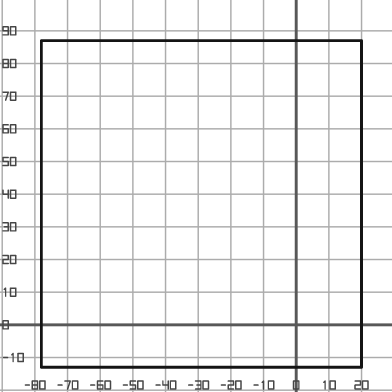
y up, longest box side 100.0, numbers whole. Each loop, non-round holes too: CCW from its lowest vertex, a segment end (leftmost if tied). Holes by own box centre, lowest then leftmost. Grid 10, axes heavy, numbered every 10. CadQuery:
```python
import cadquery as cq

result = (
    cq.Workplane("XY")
    .moveTo(-78.0, -13.0)
    .lineTo(20.0, -13.0)
    .lineTo(20.0, 87.0)
    .lineTo(-78.0, 87.0)
    .close()
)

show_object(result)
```